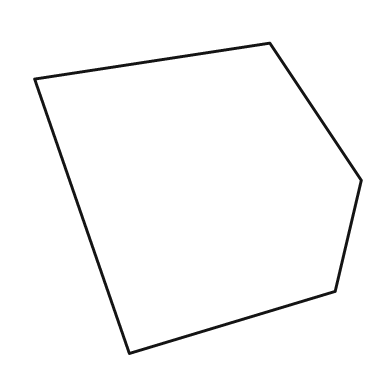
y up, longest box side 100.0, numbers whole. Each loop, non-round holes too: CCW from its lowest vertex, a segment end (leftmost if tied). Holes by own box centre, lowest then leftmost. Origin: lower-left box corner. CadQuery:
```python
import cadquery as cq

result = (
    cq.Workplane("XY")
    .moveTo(29.0, 0.0)
    .lineTo(92.0, 19.0)
    .lineTo(100.0, 53.0)
    .lineTo(72.0, 95.0)
    .lineTo(0.0, 84.0)
    .close()
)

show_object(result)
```